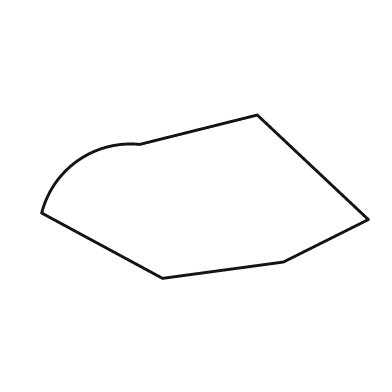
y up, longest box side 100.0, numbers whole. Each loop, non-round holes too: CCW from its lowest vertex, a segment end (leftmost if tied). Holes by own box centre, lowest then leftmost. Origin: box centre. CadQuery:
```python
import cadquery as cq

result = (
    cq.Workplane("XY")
    .moveTo(-13.0, -25.0)
    .lineTo(24.0, -20.0)
    .lineTo(50.0, -7.0)
    .lineTo(16.0, 25.0)
    .lineTo(-20.0, 16.0)
    .threePointArc((-39.0, 11.0), (-50.0, -5.0))
    .close()
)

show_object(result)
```